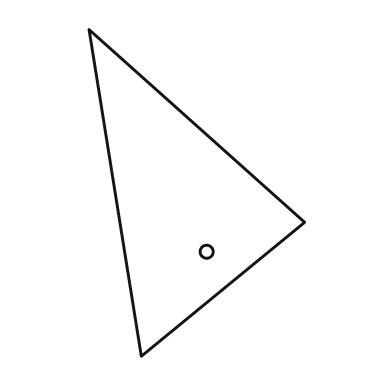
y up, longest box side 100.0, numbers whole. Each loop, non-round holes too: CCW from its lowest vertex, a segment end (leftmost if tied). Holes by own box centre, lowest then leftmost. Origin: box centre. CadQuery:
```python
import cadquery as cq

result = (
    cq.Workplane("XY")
    .moveTo(-17.0, -50.0)
    .lineTo(33.0, -9.0)
    .lineTo(-33.0, 50.0)
    .close()
    .moveTo(3.0, -18.0)
    .circle(2.0)
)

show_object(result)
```